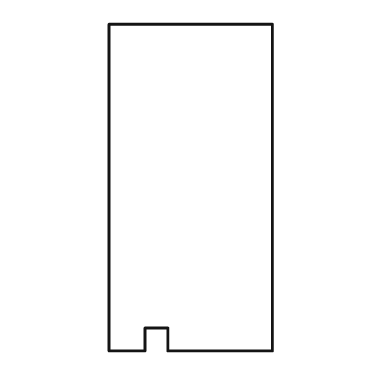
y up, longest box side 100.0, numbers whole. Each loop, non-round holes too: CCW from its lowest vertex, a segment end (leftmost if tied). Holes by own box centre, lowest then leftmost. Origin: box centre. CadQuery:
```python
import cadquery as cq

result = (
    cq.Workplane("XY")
    .moveTo(-25.0, -50.0)
    .lineTo(-14.0, -50.0)
    .lineTo(-14.0, -43.0)
    .lineTo(-7.0, -43.0)
    .lineTo(-7.0, -50.0)
    .lineTo(25.0, -50.0)
    .lineTo(25.0, 50.0)
    .lineTo(-25.0, 50.0)
    .close()
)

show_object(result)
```